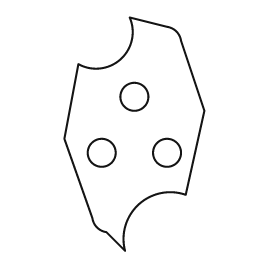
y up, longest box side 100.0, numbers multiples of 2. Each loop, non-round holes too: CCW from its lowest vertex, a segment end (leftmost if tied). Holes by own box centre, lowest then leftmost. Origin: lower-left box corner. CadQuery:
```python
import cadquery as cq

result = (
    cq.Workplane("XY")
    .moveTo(26.0, 0.0)
    .threePointArc((32.0, 20.0), (52.0, 24.0))
    .lineTo(60.0, 60.0)
    .lineTo(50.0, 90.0)
    .threePointArc((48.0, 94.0), (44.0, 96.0))
    .lineTo(28.0, 100.0)
    .threePointArc((24.0, 82.0), (6.0, 80.0))
    .lineTo(0.0, 48.0)
    .lineTo(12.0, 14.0)
    .threePointArc((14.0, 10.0), (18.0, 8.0))
    .close()
    .moveTo(16.0, 42.0)
    .circle(6.0)
    .moveTo(44.0, 42.0)
    .circle(6.0)
    .moveTo(30.0, 66.0)
    .circle(6.0)
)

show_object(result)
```